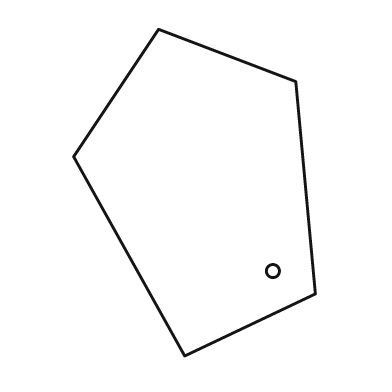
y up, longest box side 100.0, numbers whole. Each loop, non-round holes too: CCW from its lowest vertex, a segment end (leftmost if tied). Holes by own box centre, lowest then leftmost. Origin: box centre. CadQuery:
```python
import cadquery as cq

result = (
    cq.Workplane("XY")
    .moveTo(-3.0, -50.0)
    .lineTo(37.0, -31.0)
    .lineTo(31.0, 34.0)
    .lineTo(-11.0, 50.0)
    .lineTo(-37.0, 11.0)
    .close()
    .moveTo(24.0, -24.0)
    .circle(2.0)
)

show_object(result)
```